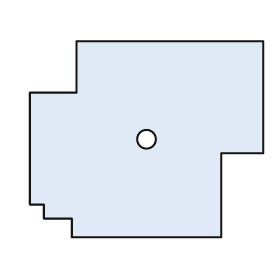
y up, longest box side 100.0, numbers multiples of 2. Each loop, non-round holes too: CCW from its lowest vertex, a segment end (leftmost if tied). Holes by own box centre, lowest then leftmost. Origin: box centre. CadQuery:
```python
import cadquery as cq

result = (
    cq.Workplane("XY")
    .moveTo(-32.0, -42.0)
    .lineTo(32.0, -42.0)
    .lineTo(32.0, -6.0)
    .lineTo(50.0, -6.0)
    .lineTo(50.0, 42.0)
    .lineTo(-30.0, 42.0)
    .lineTo(-30.0, 20.0)
    .lineTo(-50.0, 20.0)
    .lineTo(-50.0, -28.0)
    .lineTo(-44.0, -28.0)
    .lineTo(-44.0, -34.0)
    .lineTo(-32.0, -34.0)
    .close()
    .moveTo(0.0, 0.0)
    .circle(4.0)
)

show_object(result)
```